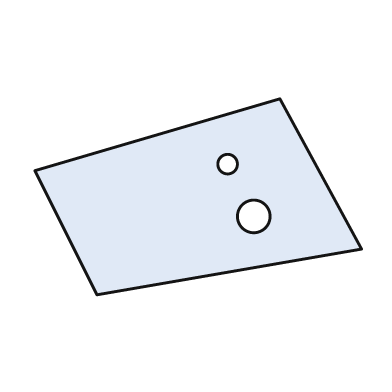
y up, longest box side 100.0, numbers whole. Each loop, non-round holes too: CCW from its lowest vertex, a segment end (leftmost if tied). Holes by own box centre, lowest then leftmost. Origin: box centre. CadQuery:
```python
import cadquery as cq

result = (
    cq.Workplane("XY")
    .moveTo(-31.0, -30.0)
    .lineTo(50.0, -16.0)
    .lineTo(25.0, 30.0)
    .lineTo(-50.0, 8.0)
    .close()
    .moveTo(17.0, -6.0)
    .circle(5.0)
    .moveTo(9.0, 10.0)
    .circle(3.0)
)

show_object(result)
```